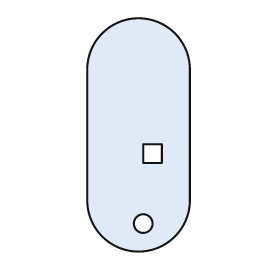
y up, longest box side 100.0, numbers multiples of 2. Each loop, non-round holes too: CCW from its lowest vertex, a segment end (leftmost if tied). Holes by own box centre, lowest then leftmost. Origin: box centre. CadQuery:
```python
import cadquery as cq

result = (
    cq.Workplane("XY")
    .moveTo(-22.0, -28.0)
    .threePointArc((0.0, -50.0), (22.0, -28.0))
    .lineTo(22.0, 28.0)
    .threePointArc((0.0, 50.0), (-22.0, 28.0))
    .close()
    .moveTo(2.0, -38.0)
    .circle(4.0)
    .moveTo(2.0, -12.0)
    .lineTo(10.0, -12.0)
    .lineTo(10.0, -4.0)
    .lineTo(2.0, -4.0)
    .close()
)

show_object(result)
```